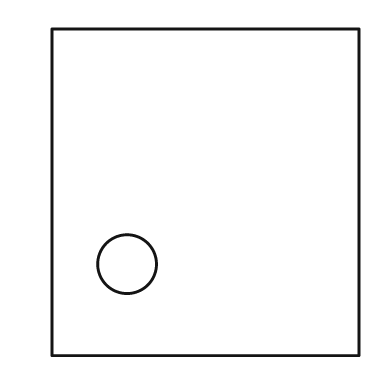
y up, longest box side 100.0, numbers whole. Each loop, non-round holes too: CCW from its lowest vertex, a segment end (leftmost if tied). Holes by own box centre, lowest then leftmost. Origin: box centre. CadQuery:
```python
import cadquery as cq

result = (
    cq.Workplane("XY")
    .moveTo(-47.0, -50.0)
    .lineTo(47.0, -50.0)
    .lineTo(47.0, 50.0)
    .lineTo(-47.0, 50.0)
    .close()
    .moveTo(-24.0, -22.0)
    .circle(9.0)
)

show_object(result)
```